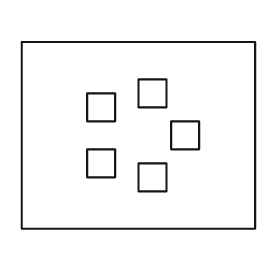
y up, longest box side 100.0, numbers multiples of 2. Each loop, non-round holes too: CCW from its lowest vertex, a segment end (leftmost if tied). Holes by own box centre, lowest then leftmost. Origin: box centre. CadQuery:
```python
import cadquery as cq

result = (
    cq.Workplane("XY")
    .moveTo(-50.0, -40.0)
    .lineTo(50.0, -40.0)
    .lineTo(50.0, 40.0)
    .lineTo(-50.0, 40.0)
    .close()
    .moveTo(0.0, -24.0)
    .lineTo(12.0, -24.0)
    .lineTo(12.0, -12.0)
    .lineTo(0.0, -12.0)
    .close()
    .moveTo(-22.0, -18.0)
    .lineTo(-10.0, -18.0)
    .lineTo(-10.0, -6.0)
    .lineTo(-22.0, -6.0)
    .close()
    .moveTo(14.0, -6.0)
    .lineTo(26.0, -6.0)
    .lineTo(26.0, 6.0)
    .lineTo(14.0, 6.0)
    .close()
    .moveTo(-22.0, 6.0)
    .lineTo(-10.0, 6.0)
    .lineTo(-10.0, 18.0)
    .lineTo(-22.0, 18.0)
    .close()
    .moveTo(0.0, 12.0)
    .lineTo(12.0, 12.0)
    .lineTo(12.0, 24.0)
    .lineTo(0.0, 24.0)
    .close()
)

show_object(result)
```